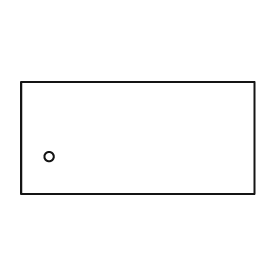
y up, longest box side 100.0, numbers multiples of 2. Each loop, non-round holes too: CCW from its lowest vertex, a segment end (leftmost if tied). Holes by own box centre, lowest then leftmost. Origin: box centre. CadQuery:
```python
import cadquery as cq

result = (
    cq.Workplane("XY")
    .moveTo(-50.0, -24.0)
    .lineTo(50.0, -24.0)
    .lineTo(50.0, 24.0)
    .lineTo(-50.0, 24.0)
    .close()
    .moveTo(-38.0, -8.0)
    .circle(2.0)
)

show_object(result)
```